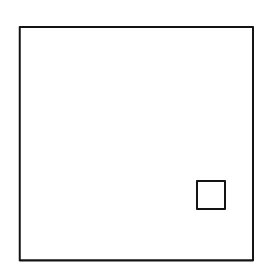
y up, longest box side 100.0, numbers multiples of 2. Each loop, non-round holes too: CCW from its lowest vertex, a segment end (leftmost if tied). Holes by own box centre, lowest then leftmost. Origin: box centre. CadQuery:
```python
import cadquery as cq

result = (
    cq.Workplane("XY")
    .moveTo(-50.0, -50.0)
    .lineTo(50.0, -50.0)
    .lineTo(50.0, 50.0)
    .lineTo(-50.0, 50.0)
    .close()
    .moveTo(26.0, -28.0)
    .lineTo(38.0, -28.0)
    .lineTo(38.0, -16.0)
    .lineTo(26.0, -16.0)
    .close()
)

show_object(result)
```